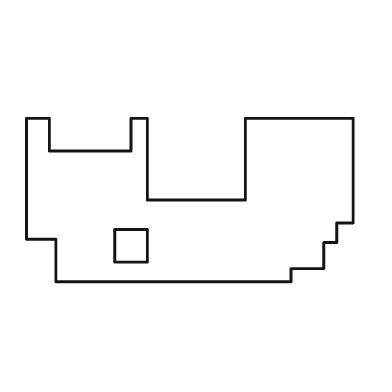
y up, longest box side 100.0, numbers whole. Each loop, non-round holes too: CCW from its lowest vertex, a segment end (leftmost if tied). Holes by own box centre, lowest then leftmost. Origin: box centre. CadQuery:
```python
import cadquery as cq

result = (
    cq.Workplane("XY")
    .moveTo(-41.0, -25.0)
    .lineTo(31.0, -25.0)
    .lineTo(31.0, -21.0)
    .lineTo(41.0, -21.0)
    .lineTo(41.0, -13.0)
    .lineTo(45.0, -13.0)
    .lineTo(45.0, -7.0)
    .lineTo(50.0, -7.0)
    .lineTo(50.0, 25.0)
    .lineTo(17.0, 25.0)
    .lineTo(17.0, 0.0)
    .lineTo(-13.0, 0.0)
    .lineTo(-13.0, 25.0)
    .lineTo(-18.0, 25.0)
    .lineTo(-18.0, 15.0)
    .lineTo(-43.0, 15.0)
    .lineTo(-43.0, 25.0)
    .lineTo(-50.0, 25.0)
    .lineTo(-50.0, -12.0)
    .lineTo(-41.0, -12.0)
    .close()
    .moveTo(-23.0, -19.0)
    .lineTo(-13.0, -19.0)
    .lineTo(-13.0, -9.0)
    .lineTo(-23.0, -9.0)
    .close()
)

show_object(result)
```